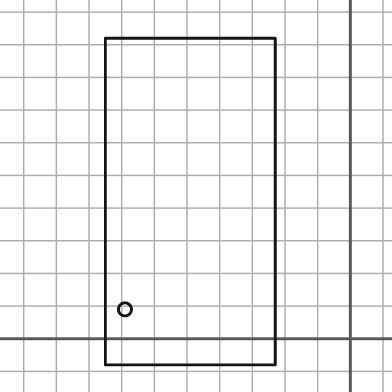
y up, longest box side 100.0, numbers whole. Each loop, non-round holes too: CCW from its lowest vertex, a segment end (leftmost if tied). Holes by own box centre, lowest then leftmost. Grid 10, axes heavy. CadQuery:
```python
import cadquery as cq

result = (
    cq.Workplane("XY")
    .moveTo(-75.0, -8.0)
    .lineTo(-23.0, -8.0)
    .lineTo(-23.0, 92.0)
    .lineTo(-75.0, 92.0)
    .close()
    .moveTo(-69.0, 9.0)
    .circle(2.0)
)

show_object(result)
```